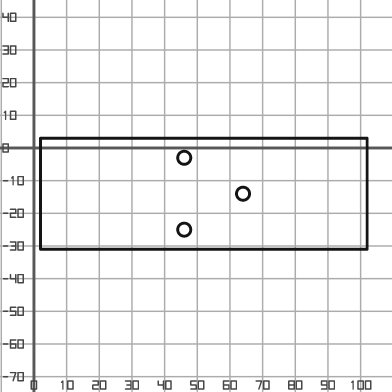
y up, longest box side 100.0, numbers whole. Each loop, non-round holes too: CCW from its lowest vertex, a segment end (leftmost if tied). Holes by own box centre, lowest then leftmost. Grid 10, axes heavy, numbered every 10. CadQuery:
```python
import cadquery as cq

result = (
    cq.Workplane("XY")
    .moveTo(2.0, -31.0)
    .lineTo(102.0, -31.0)
    .lineTo(102.0, 3.0)
    .lineTo(2.0, 3.0)
    .close()
    .moveTo(46.0, -25.0)
    .circle(2.0)
    .moveTo(64.0, -14.0)
    .circle(2.0)
    .moveTo(46.0, -3.0)
    .circle(2.0)
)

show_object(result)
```